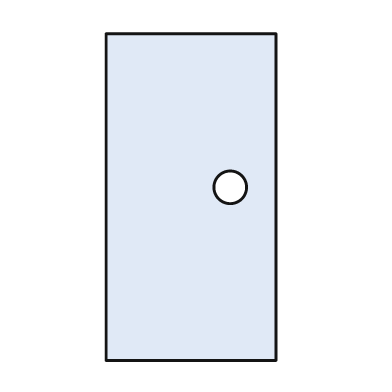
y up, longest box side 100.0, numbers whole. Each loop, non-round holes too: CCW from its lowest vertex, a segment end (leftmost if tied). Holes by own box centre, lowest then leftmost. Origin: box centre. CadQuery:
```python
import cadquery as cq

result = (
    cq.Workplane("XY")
    .moveTo(-26.0, -50.0)
    .lineTo(26.0, -50.0)
    .lineTo(26.0, 50.0)
    .lineTo(-26.0, 50.0)
    .close()
    .moveTo(12.0, 3.0)
    .circle(5.0)
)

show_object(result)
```